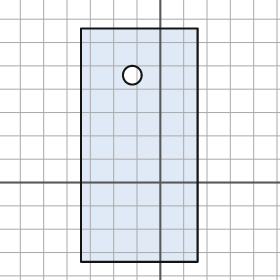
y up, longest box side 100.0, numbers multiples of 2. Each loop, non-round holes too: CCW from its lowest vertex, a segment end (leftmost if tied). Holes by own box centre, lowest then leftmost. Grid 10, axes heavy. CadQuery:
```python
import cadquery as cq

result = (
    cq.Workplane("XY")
    .moveTo(-34.0, -34.0)
    .lineTo(16.0, -34.0)
    .lineTo(16.0, 66.0)
    .lineTo(-34.0, 66.0)
    .close()
    .moveTo(-12.0, 46.0)
    .circle(4.0)
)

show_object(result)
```